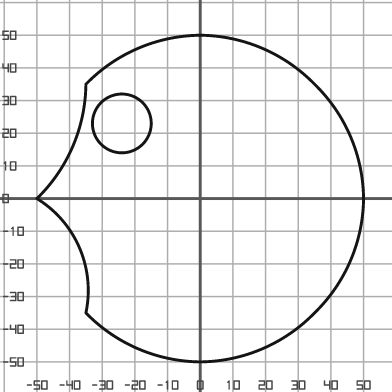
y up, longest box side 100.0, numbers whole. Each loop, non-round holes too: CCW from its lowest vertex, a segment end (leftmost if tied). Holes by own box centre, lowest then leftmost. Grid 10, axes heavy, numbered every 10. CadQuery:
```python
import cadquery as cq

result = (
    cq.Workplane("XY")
    .moveTo(0.0, -50.0)
    .threePointArc((19.0, -46.0), (35.0, -35.0))
    .threePointArc((46.0, -19.0), (50.0, 0.0))
    .threePointArc((46.0, 19.0), (35.0, 35.0))
    .threePointArc((19.0, 46.0), (0.0, 50.0))
    .threePointArc((-19.0, 46.0), (-35.0, 35.0))
    .threePointArc((-39.0, 16.0), (-50.0, 0.0))
    .threePointArc((-37.0, -15.0), (-35.0, -35.0))
    .threePointArc((-19.0, -46.0), (0.0, -50.0))
    .close()
    .moveTo(-24.0, 23.0)
    .circle(9.0)
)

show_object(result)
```